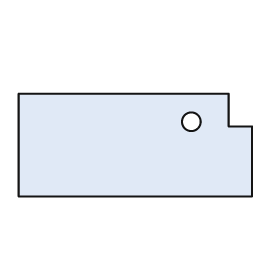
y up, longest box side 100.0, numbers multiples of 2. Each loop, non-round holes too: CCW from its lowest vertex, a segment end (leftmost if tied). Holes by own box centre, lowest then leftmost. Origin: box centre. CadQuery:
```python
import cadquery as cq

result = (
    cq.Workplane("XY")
    .moveTo(-50.0, -22.0)
    .lineTo(50.0, -22.0)
    .lineTo(50.0, 8.0)
    .lineTo(40.0, 8.0)
    .lineTo(40.0, 22.0)
    .lineTo(-50.0, 22.0)
    .close()
    .moveTo(24.0, 10.0)
    .circle(4.0)
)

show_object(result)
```